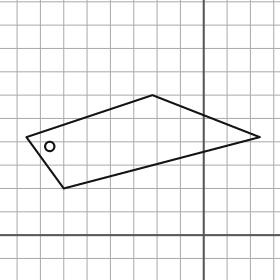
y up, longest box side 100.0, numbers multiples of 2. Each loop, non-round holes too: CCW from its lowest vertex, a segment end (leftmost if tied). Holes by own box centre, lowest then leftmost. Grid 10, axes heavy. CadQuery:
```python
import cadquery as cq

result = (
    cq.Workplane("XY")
    .moveTo(-60.0, 20.0)
    .lineTo(24.0, 42.0)
    .lineTo(-22.0, 60.0)
    .lineTo(-76.0, 42.0)
    .close()
    .moveTo(-66.0, 38.0)
    .circle(2.0)
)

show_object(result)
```